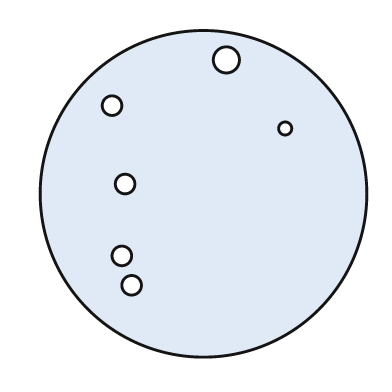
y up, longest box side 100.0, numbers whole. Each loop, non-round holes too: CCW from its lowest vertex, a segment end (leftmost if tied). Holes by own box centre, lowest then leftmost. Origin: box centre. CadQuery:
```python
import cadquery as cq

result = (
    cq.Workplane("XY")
    .moveTo(0.0, 0.0)
    .circle(50.0)
    .moveTo(-22.0, -28.0)
    .circle(3.0)
    .moveTo(-25.0, -19.0)
    .circle(3.0)
    .moveTo(-24.0, 3.0)
    .circle(3.0)
    .moveTo(25.0, 20.0)
    .circle(2.0)
    .moveTo(-28.0, 27.0)
    .circle(3.0)
    .moveTo(7.0, 41.0)
    .circle(4.0)
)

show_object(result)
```